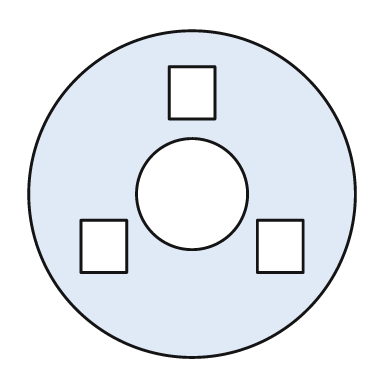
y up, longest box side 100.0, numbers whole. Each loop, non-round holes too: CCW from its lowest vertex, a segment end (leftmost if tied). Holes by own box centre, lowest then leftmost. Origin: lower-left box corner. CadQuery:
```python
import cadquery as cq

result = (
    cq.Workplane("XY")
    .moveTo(50.0, 50.0)
    .circle(50.0)
    .moveTo(16.0, 26.0)
    .lineTo(30.0, 26.0)
    .lineTo(30.0, 42.0)
    .lineTo(16.0, 42.0)
    .close()
    .moveTo(70.0, 26.0)
    .lineTo(84.0, 26.0)
    .lineTo(84.0, 42.0)
    .lineTo(70.0, 42.0)
    .close()
    .moveTo(50.0, 50.0)
    .circle(17.0)
    .moveTo(43.0, 73.0)
    .lineTo(57.0, 73.0)
    .lineTo(57.0, 89.0)
    .lineTo(43.0, 89.0)
    .close()
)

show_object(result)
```